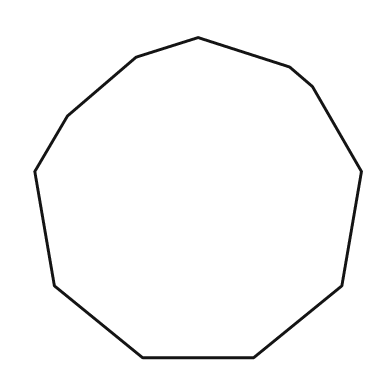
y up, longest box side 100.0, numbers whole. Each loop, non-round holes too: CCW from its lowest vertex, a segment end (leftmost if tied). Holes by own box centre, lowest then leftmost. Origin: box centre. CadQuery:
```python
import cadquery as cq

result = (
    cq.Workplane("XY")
    .moveTo(-17.0, -49.0)
    .lineTo(17.0, -49.0)
    .lineTo(44.0, -27.0)
    .lineTo(50.0, 8.0)
    .lineTo(35.0, 34.0)
    .lineTo(28.0, 40.0)
    .lineTo(0.0, 49.0)
    .lineTo(-19.0, 43.0)
    .lineTo(-40.0, 25.0)
    .lineTo(-50.0, 8.0)
    .lineTo(-44.0, -27.0)
    .close()
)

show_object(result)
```